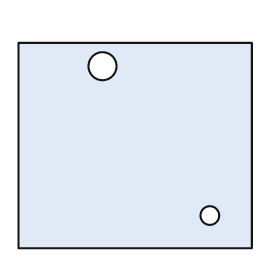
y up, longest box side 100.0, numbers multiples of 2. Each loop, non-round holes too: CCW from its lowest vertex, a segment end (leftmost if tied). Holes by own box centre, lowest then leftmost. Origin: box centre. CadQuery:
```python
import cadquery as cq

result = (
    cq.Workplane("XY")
    .moveTo(-50.0, -44.0)
    .lineTo(50.0, -44.0)
    .lineTo(50.0, 44.0)
    .lineTo(-50.0, 44.0)
    .close()
    .moveTo(32.0, -30.0)
    .circle(4.0)
    .moveTo(-14.0, 34.0)
    .circle(6.0)
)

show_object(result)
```